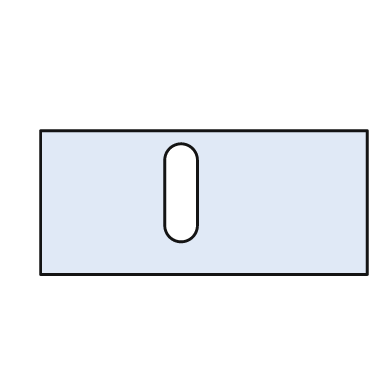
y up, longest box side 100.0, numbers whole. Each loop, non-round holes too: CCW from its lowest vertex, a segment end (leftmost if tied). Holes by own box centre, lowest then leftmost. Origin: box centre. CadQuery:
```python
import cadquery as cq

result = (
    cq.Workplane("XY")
    .moveTo(-50.0, -22.0)
    .lineTo(50.0, -22.0)
    .lineTo(50.0, 22.0)
    .lineTo(-50.0, 22.0)
    .close()
    .moveTo(-12.0, -7.0)
    .threePointArc((-7.0, -12.0), (-2.0, -7.0))
    .lineTo(-2.0, 13.0)
    .threePointArc((-7.0, 18.0), (-12.0, 13.0))
    .close()
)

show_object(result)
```